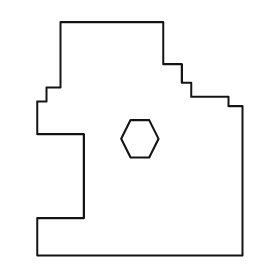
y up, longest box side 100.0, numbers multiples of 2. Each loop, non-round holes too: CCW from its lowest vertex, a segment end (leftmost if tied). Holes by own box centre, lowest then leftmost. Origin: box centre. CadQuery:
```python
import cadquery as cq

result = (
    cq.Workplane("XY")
    .moveTo(-44.0, -50.0)
    .lineTo(44.0, -50.0)
    .lineTo(44.0, 14.0)
    .lineTo(38.0, 14.0)
    .lineTo(38.0, 18.0)
    .lineTo(22.0, 18.0)
    .lineTo(22.0, 24.0)
    .lineTo(18.0, 24.0)
    .lineTo(18.0, 32.0)
    .lineTo(10.0, 32.0)
    .lineTo(10.0, 50.0)
    .lineTo(-34.0, 50.0)
    .lineTo(-34.0, 22.0)
    .lineTo(-40.0, 22.0)
    .lineTo(-40.0, 16.0)
    .lineTo(-44.0, 16.0)
    .lineTo(-44.0, 2.0)
    .lineTo(-24.0, 2.0)
    .lineTo(-24.0, -34.0)
    .lineTo(-44.0, -34.0)
    .close()
    .moveTo(-4.0, -8.0)
    .lineTo(4.0, -8.0)
    .lineTo(8.0, 0.0)
    .lineTo(4.0, 8.0)
    .lineTo(-4.0, 8.0)
    .lineTo(-8.0, 0.0)
    .close()
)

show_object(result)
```